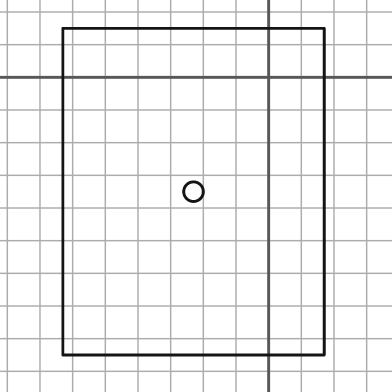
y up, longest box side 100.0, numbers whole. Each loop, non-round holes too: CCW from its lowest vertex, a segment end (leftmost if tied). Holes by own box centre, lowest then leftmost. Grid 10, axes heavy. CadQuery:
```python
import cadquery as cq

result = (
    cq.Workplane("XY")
    .moveTo(-63.0, -85.0)
    .lineTo(17.0, -85.0)
    .lineTo(17.0, 15.0)
    .lineTo(-63.0, 15.0)
    .close()
    .moveTo(-23.0, -35.0)
    .circle(3.0)
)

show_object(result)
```